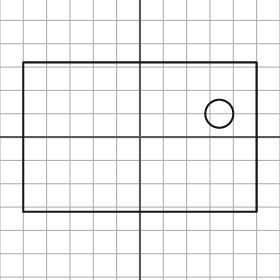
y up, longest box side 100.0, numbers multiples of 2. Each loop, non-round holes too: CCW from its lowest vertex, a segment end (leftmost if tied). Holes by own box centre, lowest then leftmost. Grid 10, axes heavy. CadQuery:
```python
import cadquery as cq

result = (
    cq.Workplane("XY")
    .moveTo(-50.0, -32.0)
    .lineTo(50.0, -32.0)
    .lineTo(50.0, 32.0)
    .lineTo(-50.0, 32.0)
    .close()
    .moveTo(34.0, 10.0)
    .circle(6.0)
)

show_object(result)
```